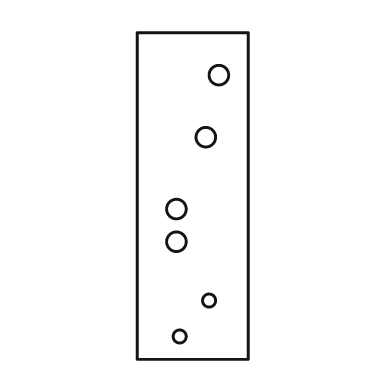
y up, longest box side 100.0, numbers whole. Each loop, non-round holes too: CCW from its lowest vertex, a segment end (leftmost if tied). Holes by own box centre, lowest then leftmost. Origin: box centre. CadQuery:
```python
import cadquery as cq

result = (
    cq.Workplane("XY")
    .moveTo(-17.0, -50.0)
    .lineTo(17.0, -50.0)
    .lineTo(17.0, 50.0)
    .lineTo(-17.0, 50.0)
    .close()
    .moveTo(-4.0, -43.0)
    .circle(2.0)
    .moveTo(5.0, -32.0)
    .circle(2.0)
    .moveTo(-5.0, -14.0)
    .circle(3.0)
    .moveTo(-5.0, -4.0)
    .circle(3.0)
    .moveTo(4.0, 18.0)
    .circle(3.0)
    .moveTo(8.0, 37.0)
    .circle(3.0)
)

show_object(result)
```